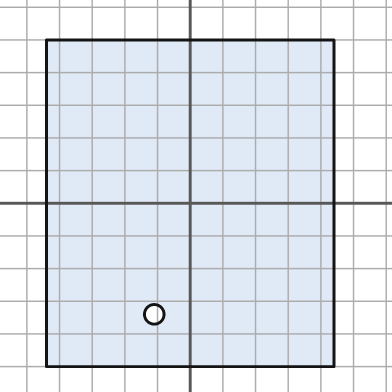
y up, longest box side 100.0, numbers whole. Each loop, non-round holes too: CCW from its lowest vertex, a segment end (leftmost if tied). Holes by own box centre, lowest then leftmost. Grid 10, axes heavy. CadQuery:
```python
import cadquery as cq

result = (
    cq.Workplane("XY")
    .moveTo(-44.0, -50.0)
    .lineTo(44.0, -50.0)
    .lineTo(44.0, 50.0)
    .lineTo(-44.0, 50.0)
    .close()
    .moveTo(-11.0, -34.0)
    .circle(3.0)
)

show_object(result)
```